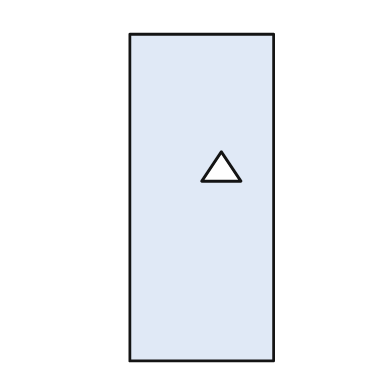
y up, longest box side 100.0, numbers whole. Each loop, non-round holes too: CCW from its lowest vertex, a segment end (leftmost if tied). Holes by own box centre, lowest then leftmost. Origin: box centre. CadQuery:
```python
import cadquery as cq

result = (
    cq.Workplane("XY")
    .moveTo(-22.0, -50.0)
    .lineTo(22.0, -50.0)
    .lineTo(22.0, 50.0)
    .lineTo(-22.0, 50.0)
    .close()
    .moveTo(0.0, 5.0)
    .lineTo(12.0, 5.0)
    .lineTo(6.0, 14.0)
    .close()
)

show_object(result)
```